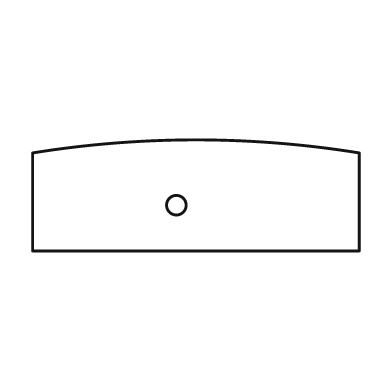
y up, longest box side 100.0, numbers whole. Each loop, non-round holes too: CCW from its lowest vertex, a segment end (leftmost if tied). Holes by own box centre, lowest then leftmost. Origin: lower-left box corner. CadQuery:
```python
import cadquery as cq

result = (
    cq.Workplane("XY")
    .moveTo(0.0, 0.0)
    .lineTo(100.0, 0.0)
    .lineTo(100.0, 30.0)
    .threePointArc((50.0, 34.0), (0.0, 30.0))
    .close()
    .moveTo(44.0, 14.0)
    .circle(3.0)
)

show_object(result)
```